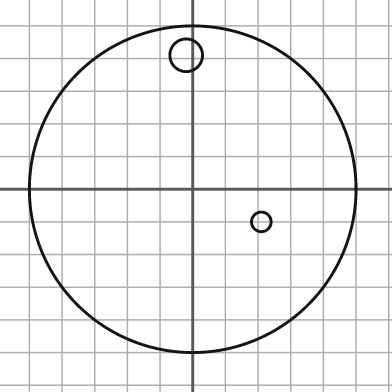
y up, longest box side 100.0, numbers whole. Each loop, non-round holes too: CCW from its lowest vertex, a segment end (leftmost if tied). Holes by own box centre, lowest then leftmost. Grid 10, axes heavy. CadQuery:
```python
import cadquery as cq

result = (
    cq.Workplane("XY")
    .moveTo(0.0, 0.0)
    .circle(50.0)
    .moveTo(21.0, -10.0)
    .circle(3.0)
    .moveTo(-2.0, 41.0)
    .circle(5.0)
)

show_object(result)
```